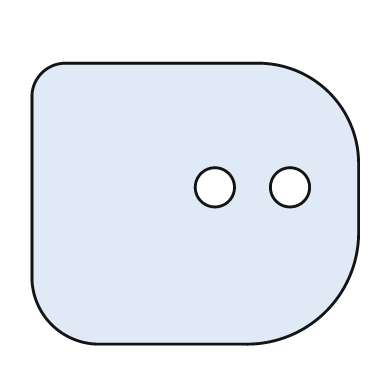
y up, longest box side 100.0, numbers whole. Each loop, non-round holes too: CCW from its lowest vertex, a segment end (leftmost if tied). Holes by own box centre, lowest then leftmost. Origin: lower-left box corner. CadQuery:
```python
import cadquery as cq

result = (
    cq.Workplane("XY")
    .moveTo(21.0, 0.0)
    .lineTo(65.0, 0.0)
    .threePointArc((90.0, 10.0), (100.0, 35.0))
    .lineTo(100.0, 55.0)
    .threePointArc((91.0, 77.0), (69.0, 86.0))
    .lineTo(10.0, 86.0)
    .threePointArc((3.0, 83.0), (0.0, 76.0))
    .lineTo(0.0, 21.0)
    .threePointArc((6.0, 6.0), (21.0, 0.0))
    .close()
    .moveTo(56.0, 48.0)
    .circle(6.0)
    .moveTo(79.0, 48.0)
    .circle(6.0)
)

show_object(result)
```